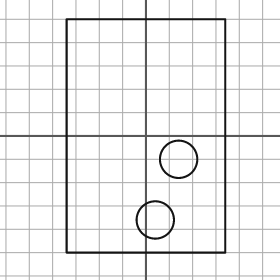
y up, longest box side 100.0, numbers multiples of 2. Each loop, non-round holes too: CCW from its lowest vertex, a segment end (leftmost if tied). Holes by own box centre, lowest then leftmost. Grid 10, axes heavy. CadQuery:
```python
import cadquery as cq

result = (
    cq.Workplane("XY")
    .moveTo(-34.0, -50.0)
    .lineTo(34.0, -50.0)
    .lineTo(34.0, 50.0)
    .lineTo(-34.0, 50.0)
    .close()
    .moveTo(4.0, -36.0)
    .circle(8.0)
    .moveTo(14.0, -10.0)
    .circle(8.0)
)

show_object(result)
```